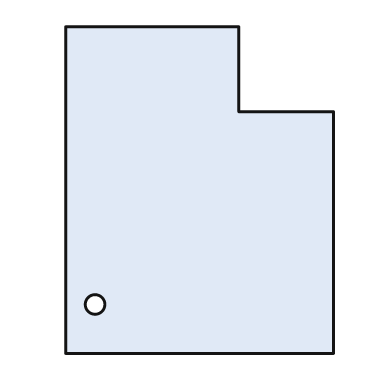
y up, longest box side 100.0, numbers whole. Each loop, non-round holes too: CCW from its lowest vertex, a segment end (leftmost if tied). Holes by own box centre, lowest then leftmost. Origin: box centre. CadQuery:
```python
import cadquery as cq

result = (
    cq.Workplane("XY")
    .moveTo(-41.0, -50.0)
    .lineTo(41.0, -50.0)
    .lineTo(41.0, 24.0)
    .lineTo(12.0, 24.0)
    .lineTo(12.0, 50.0)
    .lineTo(-41.0, 50.0)
    .close()
    .moveTo(-32.0, -35.0)
    .circle(3.0)
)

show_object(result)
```